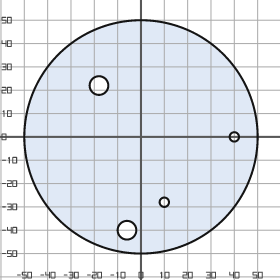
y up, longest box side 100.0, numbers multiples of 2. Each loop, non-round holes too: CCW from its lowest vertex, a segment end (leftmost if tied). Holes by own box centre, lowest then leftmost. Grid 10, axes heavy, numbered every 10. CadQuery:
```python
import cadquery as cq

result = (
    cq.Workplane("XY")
    .moveTo(0.0, 0.0)
    .circle(50.0)
    .moveTo(-6.0, -40.0)
    .circle(4.0)
    .moveTo(10.0, -28.0)
    .circle(2.0)
    .moveTo(40.0, 0.0)
    .circle(2.0)
    .moveTo(-18.0, 22.0)
    .circle(4.0)
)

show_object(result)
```